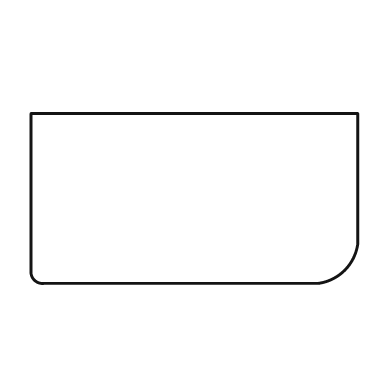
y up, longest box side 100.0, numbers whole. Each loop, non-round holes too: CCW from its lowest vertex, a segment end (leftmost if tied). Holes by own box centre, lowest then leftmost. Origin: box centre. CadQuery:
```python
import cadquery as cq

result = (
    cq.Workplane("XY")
    .moveTo(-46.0, -26.0)
    .lineTo(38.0, -26.0)
    .threePointArc((46.0, -22.0), (50.0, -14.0))
    .lineTo(50.0, 26.0)
    .lineTo(-50.0, 26.0)
    .lineTo(-50.0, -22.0)
    .threePointArc((-49.0, -25.0), (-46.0, -26.0))
    .close()
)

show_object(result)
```